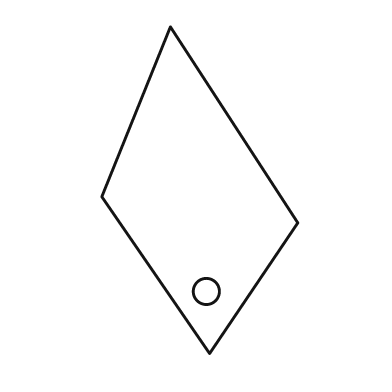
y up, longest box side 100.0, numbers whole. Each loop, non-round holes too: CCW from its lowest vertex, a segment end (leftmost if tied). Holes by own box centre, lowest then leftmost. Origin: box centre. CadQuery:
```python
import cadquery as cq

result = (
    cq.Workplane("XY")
    .moveTo(3.0, -50.0)
    .lineTo(30.0, -10.0)
    .lineTo(-9.0, 50.0)
    .lineTo(-30.0, -2.0)
    .close()
    .moveTo(2.0, -31.0)
    .circle(4.0)
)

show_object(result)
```